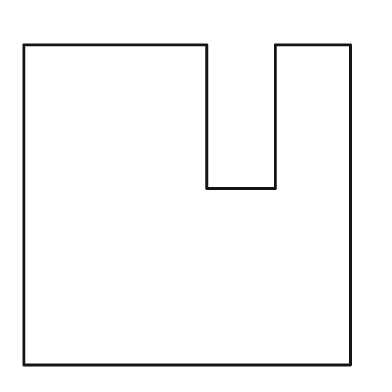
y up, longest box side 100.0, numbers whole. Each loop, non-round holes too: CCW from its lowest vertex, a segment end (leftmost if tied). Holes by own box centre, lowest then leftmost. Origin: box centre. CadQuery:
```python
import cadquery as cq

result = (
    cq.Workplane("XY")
    .moveTo(-50.0, -49.0)
    .lineTo(50.0, -49.0)
    .lineTo(50.0, 49.0)
    .lineTo(27.0, 49.0)
    .lineTo(27.0, 5.0)
    .lineTo(6.0, 5.0)
    .lineTo(6.0, 49.0)
    .lineTo(-50.0, 49.0)
    .close()
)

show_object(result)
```